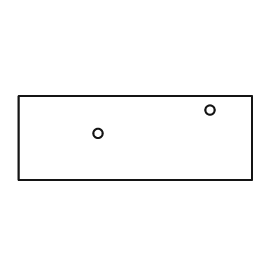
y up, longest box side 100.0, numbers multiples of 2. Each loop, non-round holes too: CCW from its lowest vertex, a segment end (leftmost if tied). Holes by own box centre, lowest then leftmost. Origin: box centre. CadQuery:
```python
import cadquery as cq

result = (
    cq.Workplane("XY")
    .moveTo(-50.0, -18.0)
    .lineTo(50.0, -18.0)
    .lineTo(50.0, 18.0)
    .lineTo(-50.0, 18.0)
    .close()
    .moveTo(-16.0, 2.0)
    .circle(2.0)
    .moveTo(32.0, 12.0)
    .circle(2.0)
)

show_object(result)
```